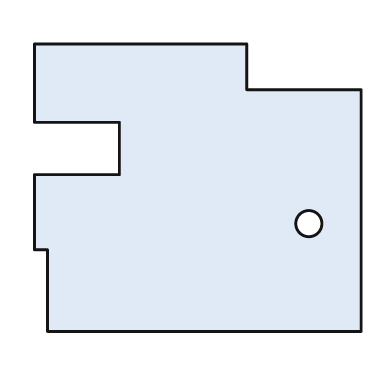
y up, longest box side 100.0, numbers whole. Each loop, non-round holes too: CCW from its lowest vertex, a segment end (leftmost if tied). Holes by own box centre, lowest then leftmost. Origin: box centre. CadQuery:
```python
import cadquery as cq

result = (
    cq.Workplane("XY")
    .moveTo(-46.0, -44.0)
    .lineTo(50.0, -44.0)
    .lineTo(50.0, 30.0)
    .lineTo(15.0, 30.0)
    .lineTo(15.0, 44.0)
    .lineTo(-50.0, 44.0)
    .lineTo(-50.0, 20.0)
    .lineTo(-24.0, 20.0)
    .lineTo(-24.0, 4.0)
    .lineTo(-50.0, 4.0)
    .lineTo(-50.0, -19.0)
    .lineTo(-46.0, -19.0)
    .close()
    .moveTo(34.0, -11.0)
    .circle(4.0)
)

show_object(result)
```